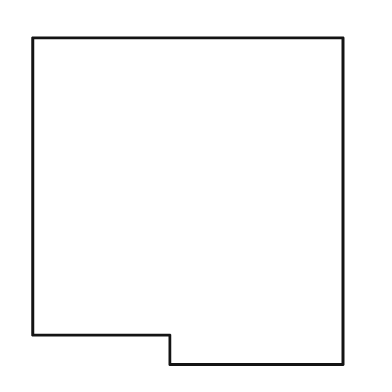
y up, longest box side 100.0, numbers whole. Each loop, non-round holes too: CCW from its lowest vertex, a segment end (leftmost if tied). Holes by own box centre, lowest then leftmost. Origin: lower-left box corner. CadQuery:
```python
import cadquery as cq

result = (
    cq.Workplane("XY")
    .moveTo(42.0, 0.0)
    .lineTo(95.0, 0.0)
    .lineTo(95.0, 100.0)
    .lineTo(0.0, 100.0)
    .lineTo(0.0, 9.0)
    .lineTo(42.0, 9.0)
    .close()
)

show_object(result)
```